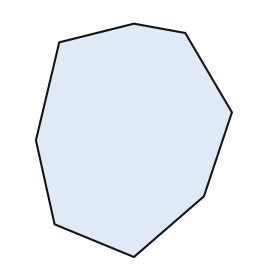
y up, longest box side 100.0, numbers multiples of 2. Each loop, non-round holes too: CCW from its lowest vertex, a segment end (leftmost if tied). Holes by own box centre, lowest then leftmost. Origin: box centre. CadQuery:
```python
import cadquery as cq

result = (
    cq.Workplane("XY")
    .moveTo(0.0, -50.0)
    .lineTo(30.0, -24.0)
    .lineTo(42.0, 12.0)
    .lineTo(22.0, 46.0)
    .lineTo(0.0, 50.0)
    .lineTo(-32.0, 42.0)
    .lineTo(-42.0, 0.0)
    .lineTo(-34.0, -36.0)
    .close()
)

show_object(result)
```